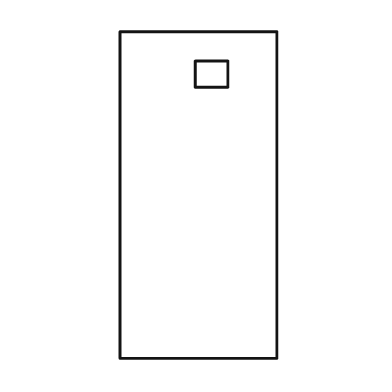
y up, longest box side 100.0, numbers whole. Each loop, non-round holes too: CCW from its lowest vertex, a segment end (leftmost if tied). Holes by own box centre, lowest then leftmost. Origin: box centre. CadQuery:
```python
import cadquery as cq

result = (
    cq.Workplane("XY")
    .moveTo(-24.0, -50.0)
    .lineTo(24.0, -50.0)
    .lineTo(24.0, 50.0)
    .lineTo(-24.0, 50.0)
    .close()
    .moveTo(-1.0, 33.0)
    .lineTo(9.0, 33.0)
    .lineTo(9.0, 41.0)
    .lineTo(-1.0, 41.0)
    .close()
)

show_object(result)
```